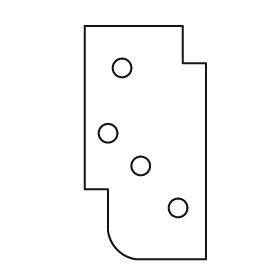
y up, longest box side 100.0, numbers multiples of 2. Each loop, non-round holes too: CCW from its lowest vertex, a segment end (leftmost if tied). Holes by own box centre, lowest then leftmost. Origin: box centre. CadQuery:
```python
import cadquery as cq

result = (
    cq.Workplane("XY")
    .moveTo(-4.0, -50.0)
    .lineTo(26.0, -50.0)
    .lineTo(26.0, 34.0)
    .lineTo(16.0, 34.0)
    .lineTo(16.0, 50.0)
    .lineTo(-26.0, 50.0)
    .lineTo(-26.0, -20.0)
    .lineTo(-16.0, -20.0)
    .lineTo(-16.0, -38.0)
    .threePointArc((-12.0, -46.0), (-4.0, -50.0))
    .close()
    .moveTo(14.0, -28.0)
    .circle(4.0)
    .moveTo(-2.0, -10.0)
    .circle(4.0)
    .moveTo(-16.0, 4.0)
    .circle(4.0)
    .moveTo(-10.0, 32.0)
    .circle(4.0)
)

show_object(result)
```